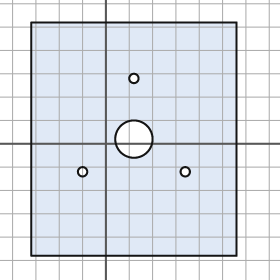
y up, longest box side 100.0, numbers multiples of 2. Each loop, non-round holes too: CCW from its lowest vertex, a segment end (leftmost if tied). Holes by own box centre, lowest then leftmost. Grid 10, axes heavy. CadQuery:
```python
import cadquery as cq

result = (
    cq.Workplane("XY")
    .moveTo(-32.0, -48.0)
    .lineTo(56.0, -48.0)
    .lineTo(56.0, 52.0)
    .lineTo(-32.0, 52.0)
    .close()
    .moveTo(-10.0, -12.0)
    .circle(2.0)
    .moveTo(34.0, -12.0)
    .circle(2.0)
    .moveTo(12.0, 2.0)
    .circle(8.0)
    .moveTo(12.0, 28.0)
    .circle(2.0)
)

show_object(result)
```